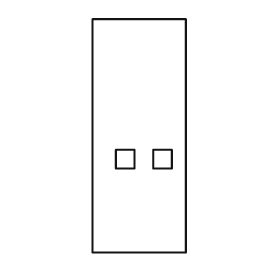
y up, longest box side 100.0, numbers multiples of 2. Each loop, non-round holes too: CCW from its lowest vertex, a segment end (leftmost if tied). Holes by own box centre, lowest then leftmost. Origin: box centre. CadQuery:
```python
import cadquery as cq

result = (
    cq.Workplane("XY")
    .moveTo(-20.0, -50.0)
    .lineTo(20.0, -50.0)
    .lineTo(20.0, 50.0)
    .lineTo(-20.0, 50.0)
    .close()
    .moveTo(-10.0, -14.0)
    .lineTo(-2.0, -14.0)
    .lineTo(-2.0, -6.0)
    .lineTo(-10.0, -6.0)
    .close()
    .moveTo(6.0, -14.0)
    .lineTo(14.0, -14.0)
    .lineTo(14.0, -6.0)
    .lineTo(6.0, -6.0)
    .close()
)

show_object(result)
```